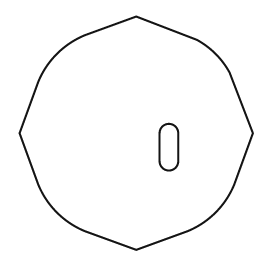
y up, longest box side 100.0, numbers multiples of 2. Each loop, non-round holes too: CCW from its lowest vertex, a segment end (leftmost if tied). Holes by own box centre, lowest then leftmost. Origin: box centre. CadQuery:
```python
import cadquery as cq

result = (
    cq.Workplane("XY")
    .moveTo(0.0, -50.0)
    .lineTo(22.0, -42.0)
    .threePointArc((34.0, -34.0), (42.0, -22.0))
    .lineTo(50.0, 0.0)
    .lineTo(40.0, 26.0)
    .threePointArc((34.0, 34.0), (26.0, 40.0))
    .lineTo(0.0, 50.0)
    .lineTo(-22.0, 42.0)
    .threePointArc((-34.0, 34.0), (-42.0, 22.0))
    .lineTo(-50.0, 0.0)
    .lineTo(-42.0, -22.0)
    .threePointArc((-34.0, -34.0), (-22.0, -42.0))
    .close()
    .moveTo(10.0, -12.0)
    .threePointArc((14.0, -16.0), (18.0, -12.0))
    .lineTo(18.0, 0.0)
    .threePointArc((14.0, 4.0), (10.0, 0.0))
    .close()
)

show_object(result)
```